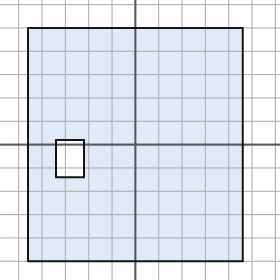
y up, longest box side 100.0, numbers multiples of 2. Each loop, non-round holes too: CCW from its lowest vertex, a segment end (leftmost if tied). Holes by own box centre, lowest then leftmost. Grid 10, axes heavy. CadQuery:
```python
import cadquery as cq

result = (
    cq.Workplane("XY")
    .moveTo(-46.0, -50.0)
    .lineTo(46.0, -50.0)
    .lineTo(46.0, 50.0)
    .lineTo(-46.0, 50.0)
    .close()
    .moveTo(-34.0, -14.0)
    .lineTo(-22.0, -14.0)
    .lineTo(-22.0, 2.0)
    .lineTo(-34.0, 2.0)
    .close()
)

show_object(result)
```